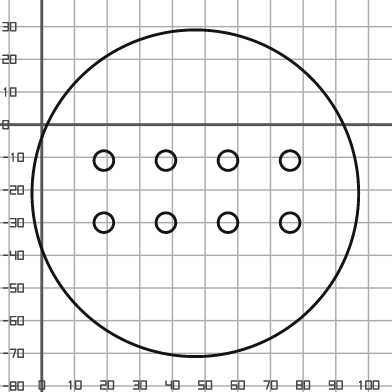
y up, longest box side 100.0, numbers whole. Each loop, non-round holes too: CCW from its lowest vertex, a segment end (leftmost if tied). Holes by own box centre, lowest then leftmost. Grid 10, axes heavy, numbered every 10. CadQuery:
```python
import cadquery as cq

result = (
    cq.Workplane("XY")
    .moveTo(47.0, -21.0)
    .circle(50.0)
    .moveTo(19.0, -30.0)
    .circle(3.0)
    .moveTo(38.0, -30.0)
    .circle(3.0)
    .moveTo(57.0, -30.0)
    .circle(3.0)
    .moveTo(76.0, -30.0)
    .circle(3.0)
    .moveTo(19.0, -11.0)
    .circle(3.0)
    .moveTo(38.0, -11.0)
    .circle(3.0)
    .moveTo(57.0, -11.0)
    .circle(3.0)
    .moveTo(76.0, -11.0)
    .circle(3.0)
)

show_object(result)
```